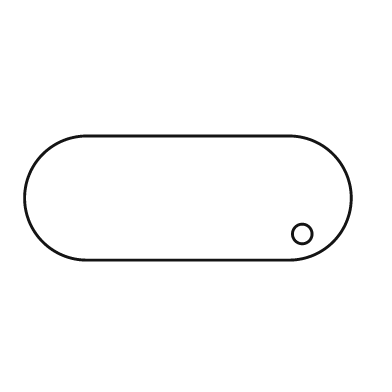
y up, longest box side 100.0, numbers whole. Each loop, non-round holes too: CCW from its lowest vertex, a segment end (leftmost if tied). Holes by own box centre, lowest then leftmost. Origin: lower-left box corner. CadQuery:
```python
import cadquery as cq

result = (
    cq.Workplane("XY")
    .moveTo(19.0, 0.0)
    .lineTo(81.0, 0.0)
    .threePointArc((100.0, 19.0), (81.0, 38.0))
    .lineTo(19.0, 38.0)
    .threePointArc((0.0, 19.0), (19.0, 0.0))
    .close()
    .moveTo(85.0, 8.0)
    .circle(3.0)
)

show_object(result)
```